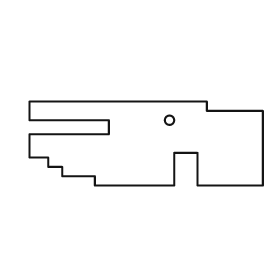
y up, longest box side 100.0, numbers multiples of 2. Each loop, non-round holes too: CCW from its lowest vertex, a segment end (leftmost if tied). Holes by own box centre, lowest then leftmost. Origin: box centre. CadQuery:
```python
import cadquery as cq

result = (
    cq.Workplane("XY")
    .moveTo(-22.0, -18.0)
    .lineTo(12.0, -18.0)
    .lineTo(12.0, -4.0)
    .lineTo(22.0, -4.0)
    .lineTo(22.0, -18.0)
    .lineTo(50.0, -18.0)
    .lineTo(50.0, 14.0)
    .lineTo(26.0, 14.0)
    .lineTo(26.0, 18.0)
    .lineTo(-50.0, 18.0)
    .lineTo(-50.0, 10.0)
    .lineTo(-16.0, 10.0)
    .lineTo(-16.0, 4.0)
    .lineTo(-50.0, 4.0)
    .lineTo(-50.0, -6.0)
    .lineTo(-42.0, -6.0)
    .lineTo(-42.0, -10.0)
    .lineTo(-36.0, -10.0)
    .lineTo(-36.0, -14.0)
    .lineTo(-22.0, -14.0)
    .close()
    .moveTo(10.0, 10.0)
    .circle(2.0)
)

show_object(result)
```